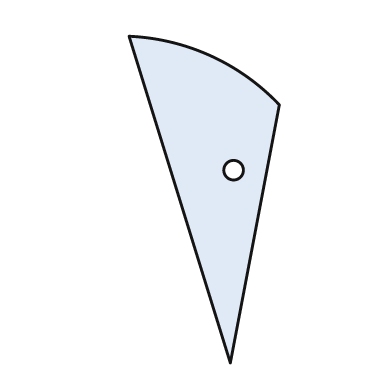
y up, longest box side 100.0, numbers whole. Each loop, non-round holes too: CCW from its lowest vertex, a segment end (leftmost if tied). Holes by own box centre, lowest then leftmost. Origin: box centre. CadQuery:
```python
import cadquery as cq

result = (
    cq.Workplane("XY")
    .moveTo(8.0, -50.0)
    .lineTo(23.0, 29.0)
    .threePointArc((2.0, 44.0), (-23.0, 50.0))
    .close()
    .moveTo(9.0, 9.0)
    .circle(3.0)
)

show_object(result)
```